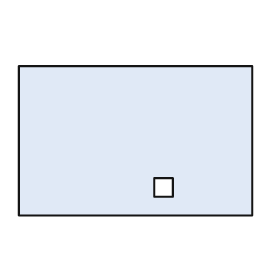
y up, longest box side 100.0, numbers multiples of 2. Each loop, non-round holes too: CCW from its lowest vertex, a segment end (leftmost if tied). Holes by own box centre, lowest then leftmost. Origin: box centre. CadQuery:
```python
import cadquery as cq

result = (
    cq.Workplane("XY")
    .moveTo(-50.0, -32.0)
    .lineTo(50.0, -32.0)
    .lineTo(50.0, 32.0)
    .lineTo(-50.0, 32.0)
    .close()
    .moveTo(8.0, -24.0)
    .lineTo(16.0, -24.0)
    .lineTo(16.0, -16.0)
    .lineTo(8.0, -16.0)
    .close()
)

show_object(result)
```